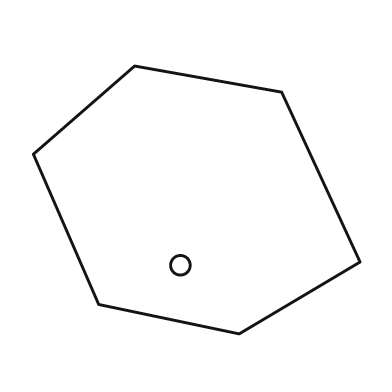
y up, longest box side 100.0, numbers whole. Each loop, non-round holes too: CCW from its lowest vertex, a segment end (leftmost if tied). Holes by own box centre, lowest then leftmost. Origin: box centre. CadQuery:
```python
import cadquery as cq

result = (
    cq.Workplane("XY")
    .moveTo(13.0, -41.0)
    .lineTo(50.0, -19.0)
    .lineTo(26.0, 33.0)
    .lineTo(-19.0, 41.0)
    .lineTo(-50.0, 14.0)
    .lineTo(-30.0, -32.0)
    .close()
    .moveTo(-5.0, -20.0)
    .circle(3.0)
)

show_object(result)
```